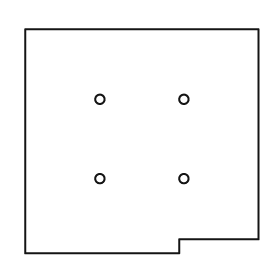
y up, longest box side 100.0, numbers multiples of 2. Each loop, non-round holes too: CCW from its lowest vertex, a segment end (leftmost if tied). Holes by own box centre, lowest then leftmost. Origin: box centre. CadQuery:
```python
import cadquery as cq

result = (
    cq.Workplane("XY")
    .moveTo(-50.0, -48.0)
    .lineTo(16.0, -48.0)
    .lineTo(16.0, -42.0)
    .lineTo(50.0, -42.0)
    .lineTo(50.0, 48.0)
    .lineTo(-50.0, 48.0)
    .close()
    .moveTo(-18.0, -16.0)
    .circle(2.0)
    .moveTo(18.0, -16.0)
    .circle(2.0)
    .moveTo(-18.0, 18.0)
    .circle(2.0)
    .moveTo(18.0, 18.0)
    .circle(2.0)
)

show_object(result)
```